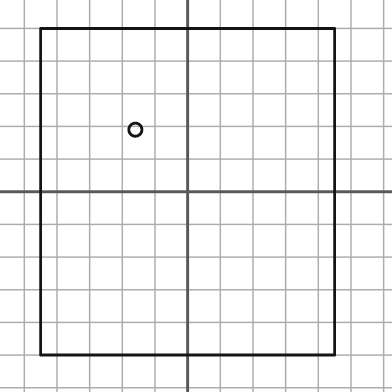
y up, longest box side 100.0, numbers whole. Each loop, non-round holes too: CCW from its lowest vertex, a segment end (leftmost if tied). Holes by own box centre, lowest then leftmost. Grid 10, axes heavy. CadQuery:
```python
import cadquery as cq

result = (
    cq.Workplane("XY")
    .moveTo(-45.0, -50.0)
    .lineTo(45.0, -50.0)
    .lineTo(45.0, 50.0)
    .lineTo(-45.0, 50.0)
    .close()
    .moveTo(-16.0, 19.0)
    .circle(2.0)
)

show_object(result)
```